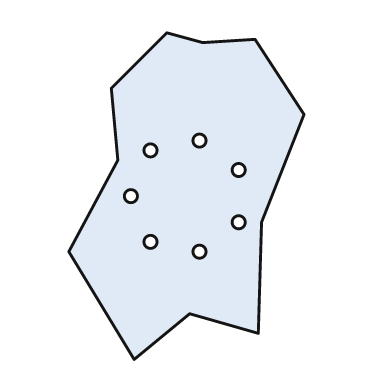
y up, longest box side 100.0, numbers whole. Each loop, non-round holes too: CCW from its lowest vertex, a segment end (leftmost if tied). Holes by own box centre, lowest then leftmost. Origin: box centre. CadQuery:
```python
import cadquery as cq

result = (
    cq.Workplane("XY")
    .moveTo(-16.0, -50.0)
    .lineTo(1.0, -36.0)
    .lineTo(22.0, -42.0)
    .lineTo(23.0, -8.0)
    .lineTo(36.0, 25.0)
    .lineTo(21.0, 48.0)
    .lineTo(5.0, 47.0)
    .lineTo(-6.0, 50.0)
    .lineTo(-23.0, 33.0)
    .lineTo(-21.0, 11.0)
    .lineTo(-36.0, -17.0)
    .close()
    .moveTo(4.0, -17.0)
    .circle(2.0)
    .moveTo(-11.0, -14.0)
    .circle(2.0)
    .moveTo(16.0, -8.0)
    .circle(2.0)
    .moveTo(-17.0, 0.0)
    .circle(2.0)
    .moveTo(16.0, 8.0)
    .circle(2.0)
    .moveTo(-11.0, 14.0)
    .circle(2.0)
    .moveTo(4.0, 17.0)
    .circle(2.0)
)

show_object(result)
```